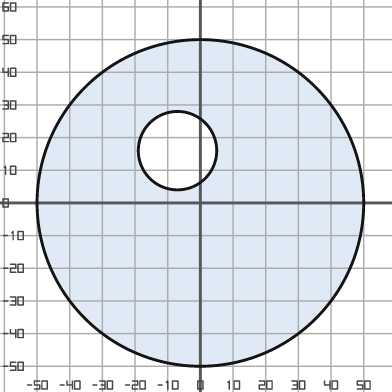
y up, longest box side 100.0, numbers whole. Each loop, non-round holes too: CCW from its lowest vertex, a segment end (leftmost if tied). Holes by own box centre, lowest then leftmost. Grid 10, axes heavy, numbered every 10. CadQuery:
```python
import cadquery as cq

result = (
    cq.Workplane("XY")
    .moveTo(0.0, 0.0)
    .circle(50.0)
    .moveTo(-7.0, 16.0)
    .circle(12.0)
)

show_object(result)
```